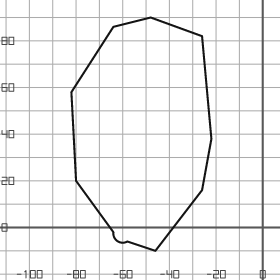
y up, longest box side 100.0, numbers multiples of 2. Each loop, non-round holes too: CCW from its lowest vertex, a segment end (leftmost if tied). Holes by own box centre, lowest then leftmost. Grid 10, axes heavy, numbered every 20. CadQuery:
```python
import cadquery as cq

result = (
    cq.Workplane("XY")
    .moveTo(-46.0, -10.0)
    .lineTo(-26.0, 16.0)
    .lineTo(-22.0, 38.0)
    .lineTo(-26.0, 82.0)
    .lineTo(-48.0, 90.0)
    .lineTo(-64.0, 86.0)
    .lineTo(-82.0, 58.0)
    .lineTo(-80.0, 20.0)
    .lineTo(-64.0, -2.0)
    .threePointArc((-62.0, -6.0), (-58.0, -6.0))
    .close()
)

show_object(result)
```